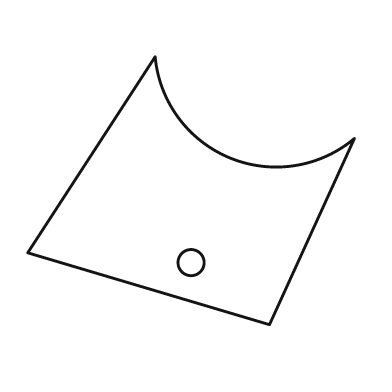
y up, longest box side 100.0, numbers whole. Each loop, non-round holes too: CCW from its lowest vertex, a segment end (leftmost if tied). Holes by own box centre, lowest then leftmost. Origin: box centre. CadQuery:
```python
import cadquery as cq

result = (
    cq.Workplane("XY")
    .moveTo(24.0, -41.0)
    .lineTo(50.0, 16.0)
    .threePointArc((12.0, 10.0), (-11.0, 41.0))
    .lineTo(-50.0, -19.0)
    .close()
    .moveTo(0.0, -22.0)
    .circle(4.0)
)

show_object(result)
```